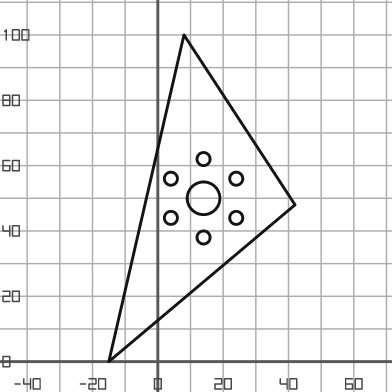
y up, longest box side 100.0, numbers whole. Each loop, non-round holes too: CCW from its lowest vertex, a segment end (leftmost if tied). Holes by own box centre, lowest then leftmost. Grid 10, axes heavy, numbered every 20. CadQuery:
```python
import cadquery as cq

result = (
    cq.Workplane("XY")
    .moveTo(-15.0, 0.0)
    .lineTo(42.0, 48.0)
    .lineTo(8.0, 100.0)
    .close()
    .moveTo(14.0, 38.0)
    .circle(2.0)
    .moveTo(4.0, 44.0)
    .circle(2.0)
    .moveTo(24.0, 44.0)
    .circle(2.0)
    .moveTo(14.0, 50.0)
    .circle(5.0)
    .moveTo(4.0, 56.0)
    .circle(2.0)
    .moveTo(24.0, 56.0)
    .circle(2.0)
    .moveTo(14.0, 62.0)
    .circle(2.0)
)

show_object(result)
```